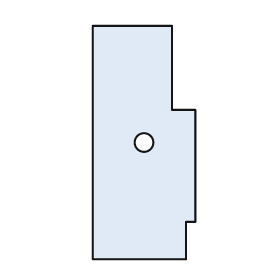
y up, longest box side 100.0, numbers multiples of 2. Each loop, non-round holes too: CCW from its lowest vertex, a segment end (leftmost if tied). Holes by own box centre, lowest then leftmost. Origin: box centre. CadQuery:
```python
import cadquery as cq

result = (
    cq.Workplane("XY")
    .moveTo(-22.0, -50.0)
    .lineTo(18.0, -50.0)
    .lineTo(18.0, -34.0)
    .lineTo(22.0, -34.0)
    .lineTo(22.0, 14.0)
    .lineTo(12.0, 14.0)
    .lineTo(12.0, 50.0)
    .lineTo(-22.0, 50.0)
    .close()
    .moveTo(0.0, 0.0)
    .circle(4.0)
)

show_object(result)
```